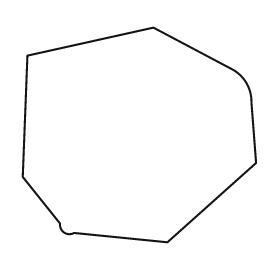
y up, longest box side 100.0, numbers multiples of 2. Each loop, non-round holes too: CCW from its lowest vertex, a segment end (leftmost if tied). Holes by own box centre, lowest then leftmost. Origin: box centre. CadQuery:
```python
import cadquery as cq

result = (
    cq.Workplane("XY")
    .moveTo(12.0, -46.0)
    .lineTo(50.0, -12.0)
    .lineTo(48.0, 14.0)
    .threePointArc((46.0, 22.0), (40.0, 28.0))
    .lineTo(6.0, 46.0)
    .lineTo(-48.0, 34.0)
    .lineTo(-50.0, -18.0)
    .lineTo(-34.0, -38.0)
    .threePointArc((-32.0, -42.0), (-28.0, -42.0))
    .close()
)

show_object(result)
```